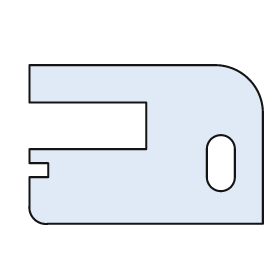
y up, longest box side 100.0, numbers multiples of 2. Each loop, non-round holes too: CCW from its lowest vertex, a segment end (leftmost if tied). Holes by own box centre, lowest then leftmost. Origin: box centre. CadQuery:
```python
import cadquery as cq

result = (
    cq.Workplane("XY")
    .moveTo(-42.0, -34.0)
    .lineTo(50.0, -34.0)
    .lineTo(50.0, 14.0)
    .threePointArc((44.0, 28.0), (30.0, 34.0))
    .lineTo(-50.0, 34.0)
    .lineTo(-50.0, 18.0)
    .lineTo(0.0, 18.0)
    .lineTo(0.0, -2.0)
    .lineTo(-50.0, -2.0)
    .lineTo(-50.0, -8.0)
    .lineTo(-42.0, -8.0)
    .lineTo(-42.0, -14.0)
    .lineTo(-50.0, -14.0)
    .lineTo(-50.0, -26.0)
    .threePointArc((-48.0, -32.0), (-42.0, -34.0))
    .close()
    .moveTo(26.0, -14.0)
    .threePointArc((32.0, -20.0), (38.0, -14.0))
    .lineTo(38.0, -2.0)
    .threePointArc((32.0, 4.0), (26.0, -2.0))
    .close()
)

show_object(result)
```